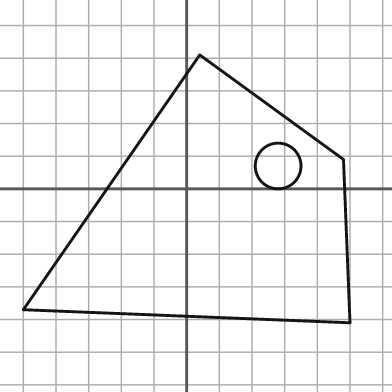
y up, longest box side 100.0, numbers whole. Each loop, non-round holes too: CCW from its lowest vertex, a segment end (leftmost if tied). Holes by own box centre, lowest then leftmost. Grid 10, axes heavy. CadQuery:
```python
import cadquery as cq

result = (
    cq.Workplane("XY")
    .moveTo(50.0, -41.0)
    .lineTo(48.0, 9.0)
    .lineTo(4.0, 41.0)
    .lineTo(-50.0, -37.0)
    .close()
    .moveTo(28.0, 7.0)
    .circle(7.0)
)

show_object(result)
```